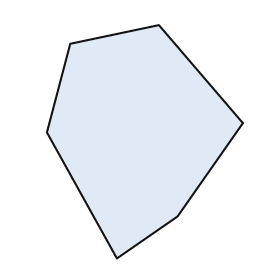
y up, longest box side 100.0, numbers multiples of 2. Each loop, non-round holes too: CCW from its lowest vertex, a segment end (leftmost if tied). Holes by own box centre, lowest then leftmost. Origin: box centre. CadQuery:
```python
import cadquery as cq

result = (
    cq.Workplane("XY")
    .moveTo(-12.0, -50.0)
    .lineTo(14.0, -32.0)
    .lineTo(42.0, 8.0)
    .lineTo(6.0, 50.0)
    .lineTo(-32.0, 42.0)
    .lineTo(-42.0, 4.0)
    .close()
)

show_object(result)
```